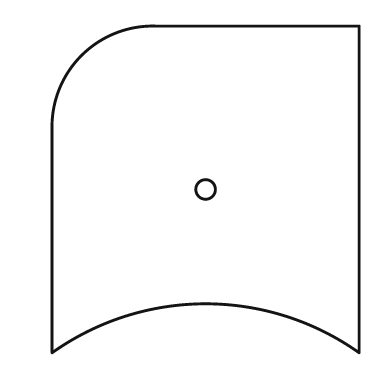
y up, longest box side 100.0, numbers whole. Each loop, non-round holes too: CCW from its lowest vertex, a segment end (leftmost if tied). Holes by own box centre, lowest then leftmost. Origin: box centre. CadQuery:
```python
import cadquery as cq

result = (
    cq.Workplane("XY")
    .moveTo(-47.0, -50.0)
    .threePointArc((0.0, -35.0), (47.0, -50.0))
    .lineTo(47.0, 50.0)
    .lineTo(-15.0, 50.0)
    .threePointArc((-38.0, 41.0), (-47.0, 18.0))
    .close()
    .moveTo(0.0, 0.0)
    .circle(3.0)
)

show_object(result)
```